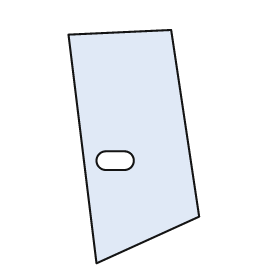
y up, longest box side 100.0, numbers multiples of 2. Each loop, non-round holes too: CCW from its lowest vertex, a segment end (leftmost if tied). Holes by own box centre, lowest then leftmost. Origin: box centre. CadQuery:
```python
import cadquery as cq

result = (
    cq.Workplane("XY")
    .moveTo(-16.0, -50.0)
    .lineTo(28.0, -30.0)
    .lineTo(16.0, 50.0)
    .lineTo(-28.0, 48.0)
    .close()
    .moveTo(-12.0, -10.0)
    .lineTo(-4.0, -10.0)
    .threePointArc((0.0, -6.0), (-4.0, -2.0))
    .lineTo(-12.0, -2.0)
    .threePointArc((-16.0, -6.0), (-12.0, -10.0))
    .close()
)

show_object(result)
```